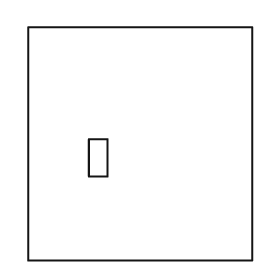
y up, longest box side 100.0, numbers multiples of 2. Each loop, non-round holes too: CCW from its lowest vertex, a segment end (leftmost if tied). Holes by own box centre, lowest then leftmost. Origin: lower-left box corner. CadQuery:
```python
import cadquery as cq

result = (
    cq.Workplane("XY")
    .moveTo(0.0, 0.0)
    .lineTo(96.0, 0.0)
    .lineTo(96.0, 100.0)
    .lineTo(0.0, 100.0)
    .close()
    .moveTo(26.0, 36.0)
    .lineTo(34.0, 36.0)
    .lineTo(34.0, 52.0)
    .lineTo(26.0, 52.0)
    .close()
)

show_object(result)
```